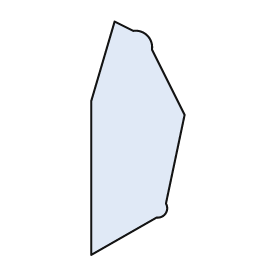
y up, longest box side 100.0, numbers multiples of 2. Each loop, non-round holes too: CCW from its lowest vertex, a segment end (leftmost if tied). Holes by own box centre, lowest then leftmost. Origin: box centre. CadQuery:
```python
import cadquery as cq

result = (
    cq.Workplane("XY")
    .moveTo(-20.0, -50.0)
    .lineTo(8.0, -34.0)
    .threePointArc((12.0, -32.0), (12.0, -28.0))
    .lineTo(20.0, 10.0)
    .lineTo(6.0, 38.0)
    .threePointArc((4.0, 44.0), (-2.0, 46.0))
    .lineTo(-10.0, 50.0)
    .lineTo(-20.0, 16.0)
    .close()
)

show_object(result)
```